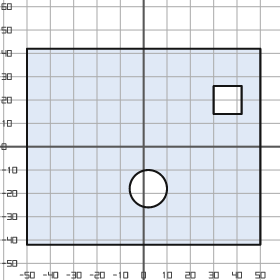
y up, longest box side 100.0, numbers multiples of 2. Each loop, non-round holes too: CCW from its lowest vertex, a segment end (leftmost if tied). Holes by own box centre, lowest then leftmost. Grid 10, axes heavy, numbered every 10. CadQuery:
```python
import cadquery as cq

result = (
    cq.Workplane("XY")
    .moveTo(-50.0, -42.0)
    .lineTo(50.0, -42.0)
    .lineTo(50.0, 42.0)
    .lineTo(-50.0, 42.0)
    .close()
    .moveTo(2.0, -18.0)
    .circle(8.0)
    .moveTo(30.0, 14.0)
    .lineTo(42.0, 14.0)
    .lineTo(42.0, 26.0)
    .lineTo(30.0, 26.0)
    .close()
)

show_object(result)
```